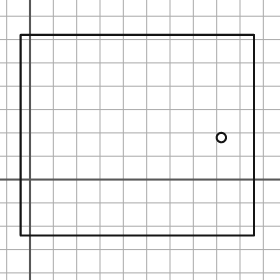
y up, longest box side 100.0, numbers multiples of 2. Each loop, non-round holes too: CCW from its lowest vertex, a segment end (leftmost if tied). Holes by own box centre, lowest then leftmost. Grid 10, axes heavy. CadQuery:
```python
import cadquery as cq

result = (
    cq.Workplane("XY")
    .moveTo(-4.0, -24.0)
    .lineTo(96.0, -24.0)
    .lineTo(96.0, 62.0)
    .lineTo(-4.0, 62.0)
    .close()
    .moveTo(82.0, 18.0)
    .circle(2.0)
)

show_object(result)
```